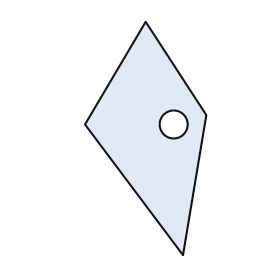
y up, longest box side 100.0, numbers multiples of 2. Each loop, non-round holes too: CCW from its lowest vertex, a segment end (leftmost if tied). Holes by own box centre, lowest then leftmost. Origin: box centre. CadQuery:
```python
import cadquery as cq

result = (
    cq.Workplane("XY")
    .moveTo(16.0, -50.0)
    .lineTo(26.0, 10.0)
    .lineTo(0.0, 50.0)
    .lineTo(-26.0, 6.0)
    .close()
    .moveTo(12.0, 6.0)
    .circle(6.0)
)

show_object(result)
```